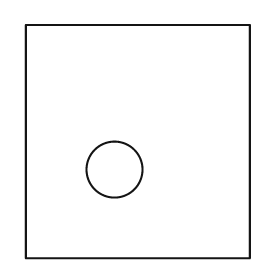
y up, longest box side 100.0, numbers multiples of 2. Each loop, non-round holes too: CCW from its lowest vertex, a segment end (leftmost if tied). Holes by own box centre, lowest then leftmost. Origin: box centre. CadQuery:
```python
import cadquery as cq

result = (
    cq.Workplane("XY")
    .moveTo(-48.0, -50.0)
    .lineTo(48.0, -50.0)
    .lineTo(48.0, 50.0)
    .lineTo(-48.0, 50.0)
    .close()
    .moveTo(-10.0, -12.0)
    .circle(12.0)
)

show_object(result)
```